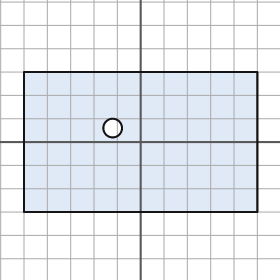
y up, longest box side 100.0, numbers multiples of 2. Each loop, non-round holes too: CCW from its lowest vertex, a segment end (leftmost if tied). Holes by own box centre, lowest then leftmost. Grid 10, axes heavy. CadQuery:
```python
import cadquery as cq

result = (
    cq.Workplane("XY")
    .moveTo(-50.0, -30.0)
    .lineTo(50.0, -30.0)
    .lineTo(50.0, 30.0)
    .lineTo(-50.0, 30.0)
    .close()
    .moveTo(-12.0, 6.0)
    .circle(4.0)
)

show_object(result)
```